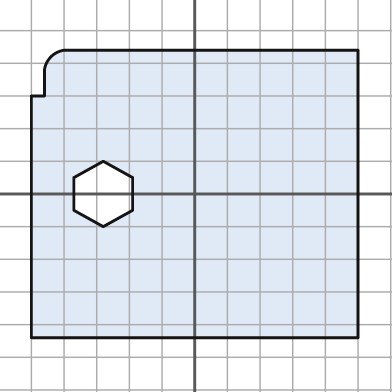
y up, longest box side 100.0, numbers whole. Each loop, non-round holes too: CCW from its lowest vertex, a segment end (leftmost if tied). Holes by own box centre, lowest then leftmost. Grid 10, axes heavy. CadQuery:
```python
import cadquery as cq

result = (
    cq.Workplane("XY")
    .moveTo(-50.0, -44.0)
    .lineTo(50.0, -44.0)
    .lineTo(50.0, 44.0)
    .lineTo(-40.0, 44.0)
    .threePointArc((-44.0, 42.0), (-46.0, 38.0))
    .lineTo(-46.0, 30.0)
    .lineTo(-50.0, 30.0)
    .close()
    .moveTo(-28.0, -10.0)
    .lineTo(-19.0, -5.0)
    .lineTo(-19.0, 5.0)
    .lineTo(-28.0, 10.0)
    .lineTo(-37.0, 5.0)
    .lineTo(-37.0, -5.0)
    .close()
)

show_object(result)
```